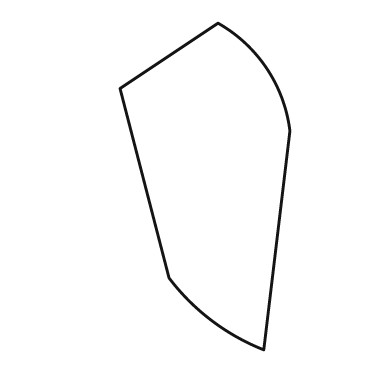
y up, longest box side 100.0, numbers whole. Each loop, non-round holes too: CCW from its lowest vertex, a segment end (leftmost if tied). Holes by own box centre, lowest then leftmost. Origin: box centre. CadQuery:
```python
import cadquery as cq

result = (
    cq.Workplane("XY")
    .moveTo(18.0, -50.0)
    .lineTo(26.0, 17.0)
    .threePointArc((19.0, 36.0), (4.0, 50.0))
    .lineTo(-26.0, 30.0)
    .lineTo(-11.0, -28.0)
    .threePointArc((2.0, -41.0), (18.0, -50.0))
    .close()
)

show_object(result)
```